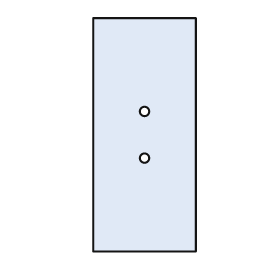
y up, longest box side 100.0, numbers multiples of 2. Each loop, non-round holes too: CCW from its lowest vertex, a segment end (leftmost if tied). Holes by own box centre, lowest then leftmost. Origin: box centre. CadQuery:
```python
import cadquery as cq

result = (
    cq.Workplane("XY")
    .moveTo(-22.0, -50.0)
    .lineTo(22.0, -50.0)
    .lineTo(22.0, 50.0)
    .lineTo(-22.0, 50.0)
    .close()
    .moveTo(0.0, -10.0)
    .circle(2.0)
    .moveTo(0.0, 10.0)
    .circle(2.0)
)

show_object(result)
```